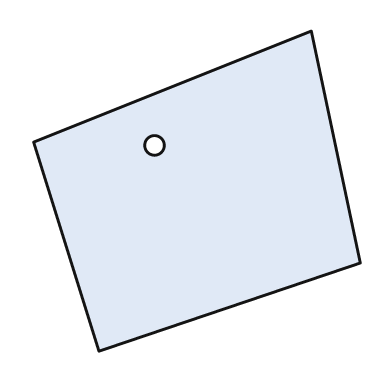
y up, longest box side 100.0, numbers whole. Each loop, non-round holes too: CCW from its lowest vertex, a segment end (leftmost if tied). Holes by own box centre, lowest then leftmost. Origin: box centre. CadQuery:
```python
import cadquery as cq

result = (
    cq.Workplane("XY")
    .moveTo(-30.0, -49.0)
    .lineTo(50.0, -22.0)
    .lineTo(35.0, 49.0)
    .lineTo(-50.0, 15.0)
    .close()
    .moveTo(-13.0, 14.0)
    .circle(3.0)
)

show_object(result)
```